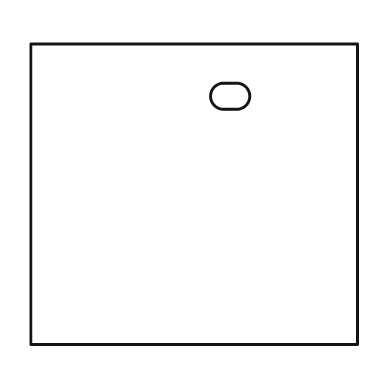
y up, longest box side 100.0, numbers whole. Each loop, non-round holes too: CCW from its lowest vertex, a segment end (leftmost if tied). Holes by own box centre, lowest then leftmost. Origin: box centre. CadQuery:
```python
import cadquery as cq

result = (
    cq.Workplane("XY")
    .moveTo(-50.0, -46.0)
    .lineTo(50.0, -46.0)
    .lineTo(50.0, 46.0)
    .lineTo(-50.0, 46.0)
    .close()
    .moveTo(9.0, 26.0)
    .lineTo(13.0, 26.0)
    .threePointArc((17.0, 30.0), (13.0, 34.0))
    .lineTo(9.0, 34.0)
    .threePointArc((5.0, 30.0), (9.0, 26.0))
    .close()
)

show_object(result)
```